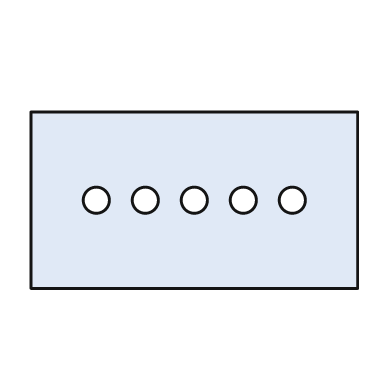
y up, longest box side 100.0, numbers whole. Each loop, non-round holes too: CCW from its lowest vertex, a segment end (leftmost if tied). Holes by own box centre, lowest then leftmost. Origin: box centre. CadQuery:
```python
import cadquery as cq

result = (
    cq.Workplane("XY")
    .moveTo(-50.0, -27.0)
    .lineTo(50.0, -27.0)
    .lineTo(50.0, 27.0)
    .lineTo(-50.0, 27.0)
    .close()
    .moveTo(-30.0, 0.0)
    .circle(4.0)
    .moveTo(-15.0, 0.0)
    .circle(4.0)
    .moveTo(0.0, 0.0)
    .circle(4.0)
    .moveTo(15.0, 0.0)
    .circle(4.0)
    .moveTo(30.0, 0.0)
    .circle(4.0)
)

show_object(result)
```